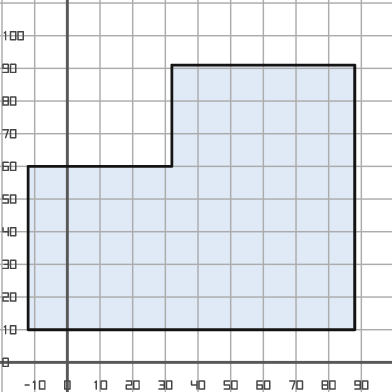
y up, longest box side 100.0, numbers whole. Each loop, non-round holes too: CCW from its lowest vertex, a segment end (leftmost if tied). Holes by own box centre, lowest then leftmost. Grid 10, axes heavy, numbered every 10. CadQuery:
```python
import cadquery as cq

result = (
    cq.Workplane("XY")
    .moveTo(-12.0, 10.0)
    .lineTo(88.0, 10.0)
    .lineTo(88.0, 91.0)
    .lineTo(32.0, 91.0)
    .lineTo(32.0, 60.0)
    .lineTo(-12.0, 60.0)
    .close()
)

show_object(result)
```